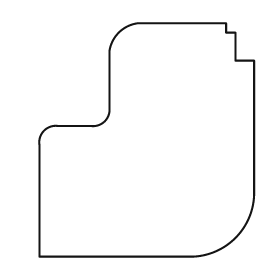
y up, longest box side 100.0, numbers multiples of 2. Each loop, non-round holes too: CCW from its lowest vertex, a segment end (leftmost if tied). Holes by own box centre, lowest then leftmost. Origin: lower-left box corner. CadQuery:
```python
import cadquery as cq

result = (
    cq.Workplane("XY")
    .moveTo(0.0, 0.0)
    .lineTo(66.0, 0.0)
    .threePointArc((84.0, 8.0), (92.0, 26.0))
    .lineTo(92.0, 84.0)
    .lineTo(84.0, 84.0)
    .lineTo(84.0, 96.0)
    .lineTo(80.0, 96.0)
    .lineTo(80.0, 100.0)
    .lineTo(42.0, 100.0)
    .threePointArc((34.0, 96.0), (30.0, 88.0))
    .lineTo(30.0, 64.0)
    .threePointArc((28.0, 58.0), (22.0, 56.0))
    .lineTo(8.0, 56.0)
    .threePointArc((2.0, 54.0), (0.0, 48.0))
    .close()
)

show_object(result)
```